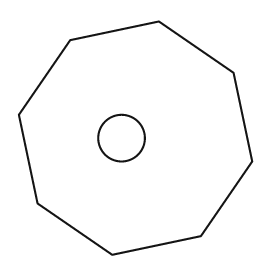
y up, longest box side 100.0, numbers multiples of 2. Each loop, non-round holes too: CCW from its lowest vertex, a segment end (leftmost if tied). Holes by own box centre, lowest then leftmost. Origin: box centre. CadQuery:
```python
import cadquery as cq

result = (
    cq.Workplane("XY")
    .moveTo(-10.0, -50.0)
    .lineTo(28.0, -42.0)
    .lineTo(50.0, -10.0)
    .lineTo(42.0, 28.0)
    .lineTo(10.0, 50.0)
    .lineTo(-28.0, 42.0)
    .lineTo(-50.0, 10.0)
    .lineTo(-42.0, -28.0)
    .close()
    .moveTo(-6.0, 0.0)
    .circle(10.0)
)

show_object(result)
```